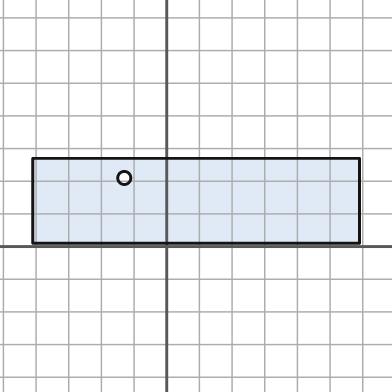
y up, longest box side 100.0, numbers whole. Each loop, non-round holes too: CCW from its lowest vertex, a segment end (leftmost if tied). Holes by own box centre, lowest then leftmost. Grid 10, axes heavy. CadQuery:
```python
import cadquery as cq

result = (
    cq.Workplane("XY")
    .moveTo(-41.0, 1.0)
    .lineTo(59.0, 1.0)
    .lineTo(59.0, 27.0)
    .lineTo(-41.0, 27.0)
    .close()
    .moveTo(-13.0, 21.0)
    .circle(2.0)
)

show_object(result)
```